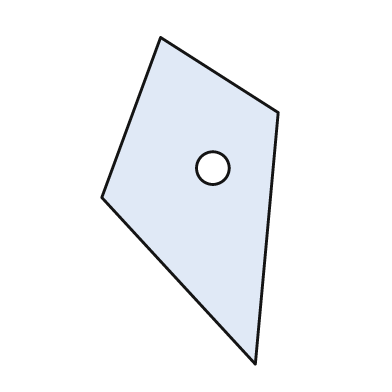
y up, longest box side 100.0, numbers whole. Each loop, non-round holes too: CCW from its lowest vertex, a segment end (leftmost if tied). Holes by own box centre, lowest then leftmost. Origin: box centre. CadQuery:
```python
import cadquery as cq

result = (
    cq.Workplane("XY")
    .moveTo(20.0, -50.0)
    .lineTo(27.0, 27.0)
    .lineTo(-9.0, 50.0)
    .lineTo(-27.0, 1.0)
    .close()
    .moveTo(7.0, 10.0)
    .circle(5.0)
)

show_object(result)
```